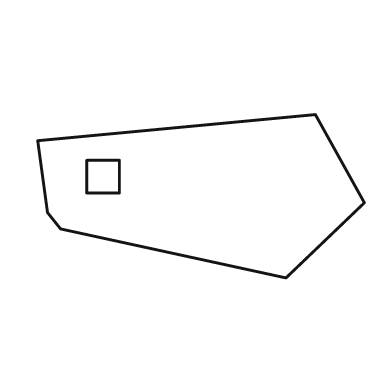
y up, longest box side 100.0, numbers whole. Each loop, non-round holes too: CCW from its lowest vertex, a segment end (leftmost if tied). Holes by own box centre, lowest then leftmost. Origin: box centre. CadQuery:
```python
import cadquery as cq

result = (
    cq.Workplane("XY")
    .moveTo(26.0, -25.0)
    .lineTo(50.0, -2.0)
    .lineTo(35.0, 25.0)
    .lineTo(-50.0, 17.0)
    .lineTo(-47.0, -5.0)
    .lineTo(-43.0, -10.0)
    .close()
    .moveTo(-35.0, 1.0)
    .lineTo(-25.0, 1.0)
    .lineTo(-25.0, 11.0)
    .lineTo(-35.0, 11.0)
    .close()
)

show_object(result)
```